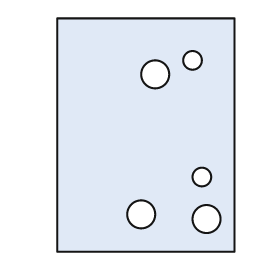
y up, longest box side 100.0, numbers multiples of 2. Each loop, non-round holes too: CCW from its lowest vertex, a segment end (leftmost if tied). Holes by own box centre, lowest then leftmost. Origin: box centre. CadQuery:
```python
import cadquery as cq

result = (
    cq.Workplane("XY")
    .moveTo(-38.0, -50.0)
    .lineTo(38.0, -50.0)
    .lineTo(38.0, 50.0)
    .lineTo(-38.0, 50.0)
    .close()
    .moveTo(26.0, -36.0)
    .circle(6.0)
    .moveTo(-2.0, -34.0)
    .circle(6.0)
    .moveTo(24.0, -18.0)
    .circle(4.0)
    .moveTo(4.0, 26.0)
    .circle(6.0)
    .moveTo(20.0, 32.0)
    .circle(4.0)
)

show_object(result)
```